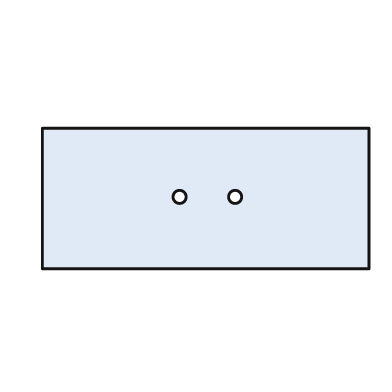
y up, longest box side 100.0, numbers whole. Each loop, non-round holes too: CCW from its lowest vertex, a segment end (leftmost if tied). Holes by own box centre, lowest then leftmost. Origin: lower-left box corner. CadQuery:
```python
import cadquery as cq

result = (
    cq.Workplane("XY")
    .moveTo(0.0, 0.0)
    .lineTo(100.0, 0.0)
    .lineTo(100.0, 43.0)
    .lineTo(0.0, 43.0)
    .close()
    .moveTo(42.0, 22.0)
    .circle(2.0)
    .moveTo(59.0, 22.0)
    .circle(2.0)
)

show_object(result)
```